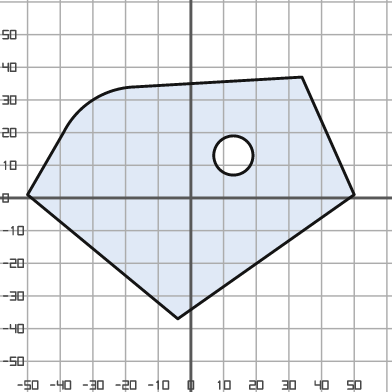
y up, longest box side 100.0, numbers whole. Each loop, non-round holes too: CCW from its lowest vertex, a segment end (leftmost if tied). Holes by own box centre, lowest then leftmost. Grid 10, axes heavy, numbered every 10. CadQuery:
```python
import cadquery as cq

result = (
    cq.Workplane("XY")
    .moveTo(-4.0, -37.0)
    .lineTo(50.0, 1.0)
    .lineTo(34.0, 37.0)
    .lineTo(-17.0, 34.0)
    .threePointArc((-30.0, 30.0), (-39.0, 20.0))
    .lineTo(-50.0, 1.0)
    .close()
    .moveTo(13.0, 13.0)
    .circle(6.0)
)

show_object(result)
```